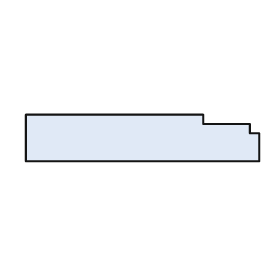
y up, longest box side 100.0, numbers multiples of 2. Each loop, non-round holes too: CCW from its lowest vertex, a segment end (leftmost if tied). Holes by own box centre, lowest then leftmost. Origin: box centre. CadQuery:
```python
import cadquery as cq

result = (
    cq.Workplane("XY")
    .moveTo(-50.0, -10.0)
    .lineTo(50.0, -10.0)
    .lineTo(50.0, 2.0)
    .lineTo(46.0, 2.0)
    .lineTo(46.0, 6.0)
    .lineTo(26.0, 6.0)
    .lineTo(26.0, 10.0)
    .lineTo(-50.0, 10.0)
    .close()
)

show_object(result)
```